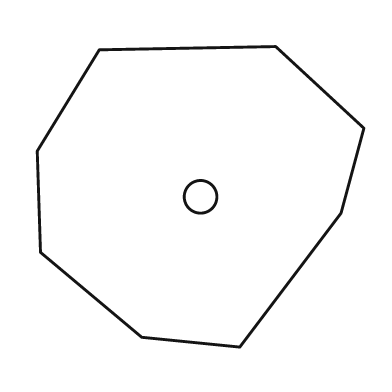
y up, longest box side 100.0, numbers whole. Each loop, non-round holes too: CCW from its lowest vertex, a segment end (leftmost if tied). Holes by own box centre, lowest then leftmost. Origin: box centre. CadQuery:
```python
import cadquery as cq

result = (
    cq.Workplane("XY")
    .moveTo(12.0, -46.0)
    .lineTo(43.0, -5.0)
    .lineTo(50.0, 21.0)
    .lineTo(23.0, 46.0)
    .lineTo(-31.0, 45.0)
    .lineTo(-50.0, 14.0)
    .lineTo(-49.0, -17.0)
    .lineTo(-18.0, -43.0)
    .close()
    .moveTo(0.0, 0.0)
    .circle(5.0)
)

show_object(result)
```